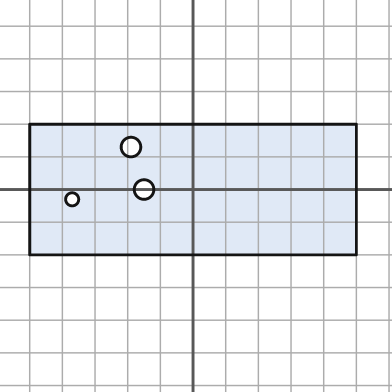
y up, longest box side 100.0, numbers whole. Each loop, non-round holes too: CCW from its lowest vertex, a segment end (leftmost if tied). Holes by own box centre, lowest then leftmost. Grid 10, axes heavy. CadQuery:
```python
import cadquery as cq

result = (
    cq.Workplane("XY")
    .moveTo(-50.0, -20.0)
    .lineTo(50.0, -20.0)
    .lineTo(50.0, 20.0)
    .lineTo(-50.0, 20.0)
    .close()
    .moveTo(-37.0, -3.0)
    .circle(2.0)
    .moveTo(-15.0, 0.0)
    .circle(3.0)
    .moveTo(-19.0, 13.0)
    .circle(3.0)
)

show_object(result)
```